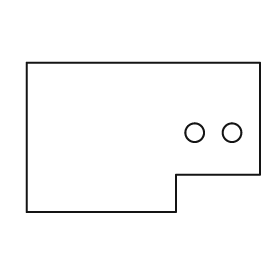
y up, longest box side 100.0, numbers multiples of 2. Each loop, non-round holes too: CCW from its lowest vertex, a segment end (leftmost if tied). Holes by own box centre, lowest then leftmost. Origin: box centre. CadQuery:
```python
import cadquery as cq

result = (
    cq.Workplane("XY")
    .moveTo(-50.0, -32.0)
    .lineTo(14.0, -32.0)
    .lineTo(14.0, -16.0)
    .lineTo(50.0, -16.0)
    .lineTo(50.0, 32.0)
    .lineTo(-50.0, 32.0)
    .close()
    .moveTo(22.0, 2.0)
    .circle(4.0)
    .moveTo(38.0, 2.0)
    .circle(4.0)
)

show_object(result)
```